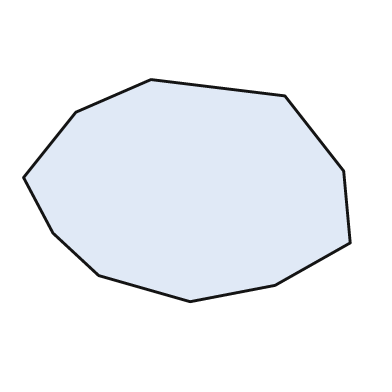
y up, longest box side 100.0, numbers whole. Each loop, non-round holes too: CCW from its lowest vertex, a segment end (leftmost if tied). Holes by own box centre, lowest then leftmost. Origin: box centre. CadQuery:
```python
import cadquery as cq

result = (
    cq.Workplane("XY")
    .moveTo(1.0, -34.0)
    .lineTo(27.0, -29.0)
    .lineTo(50.0, -16.0)
    .lineTo(48.0, 6.0)
    .lineTo(30.0, 29.0)
    .lineTo(-11.0, 34.0)
    .lineTo(-34.0, 24.0)
    .lineTo(-50.0, 4.0)
    .lineTo(-41.0, -13.0)
    .lineTo(-27.0, -26.0)
    .close()
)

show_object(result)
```